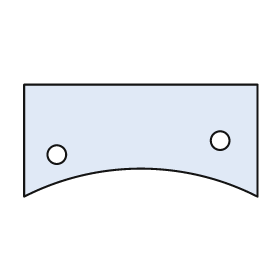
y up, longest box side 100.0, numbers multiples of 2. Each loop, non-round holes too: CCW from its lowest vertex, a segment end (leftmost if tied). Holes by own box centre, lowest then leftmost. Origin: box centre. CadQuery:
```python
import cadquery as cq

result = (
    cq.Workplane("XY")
    .moveTo(-50.0, -24.0)
    .threePointArc((0.0, -12.0), (50.0, -24.0))
    .lineTo(50.0, 24.0)
    .lineTo(-50.0, 24.0)
    .close()
    .moveTo(-36.0, -6.0)
    .circle(4.0)
    .moveTo(34.0, 0.0)
    .circle(4.0)
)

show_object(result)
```